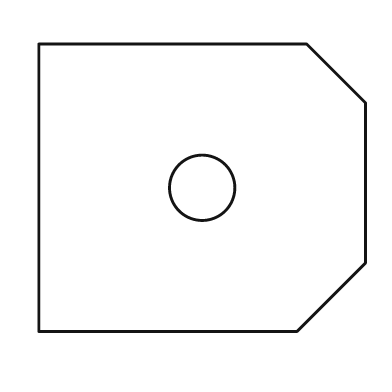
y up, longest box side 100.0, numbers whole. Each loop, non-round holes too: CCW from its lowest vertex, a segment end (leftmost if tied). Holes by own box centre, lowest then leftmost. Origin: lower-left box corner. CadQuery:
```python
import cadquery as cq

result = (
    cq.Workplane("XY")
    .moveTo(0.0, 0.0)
    .lineTo(79.0, 0.0)
    .lineTo(100.0, 21.0)
    .lineTo(100.0, 70.0)
    .lineTo(82.0, 88.0)
    .lineTo(0.0, 88.0)
    .close()
    .moveTo(50.0, 44.0)
    .circle(10.0)
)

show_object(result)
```